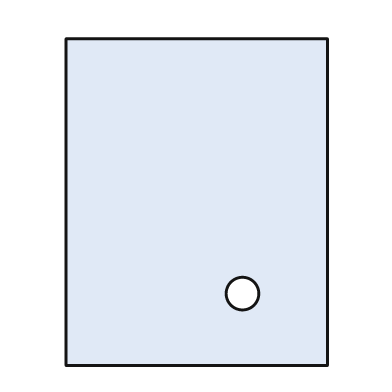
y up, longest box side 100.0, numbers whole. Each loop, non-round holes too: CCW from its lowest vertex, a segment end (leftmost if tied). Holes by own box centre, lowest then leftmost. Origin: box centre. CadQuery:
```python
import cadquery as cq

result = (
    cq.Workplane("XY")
    .moveTo(-40.0, -50.0)
    .lineTo(40.0, -50.0)
    .lineTo(40.0, 50.0)
    .lineTo(-40.0, 50.0)
    .close()
    .moveTo(14.0, -28.0)
    .circle(5.0)
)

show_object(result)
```